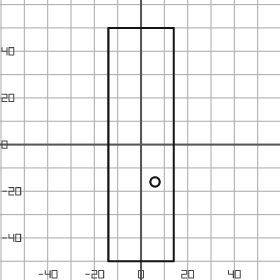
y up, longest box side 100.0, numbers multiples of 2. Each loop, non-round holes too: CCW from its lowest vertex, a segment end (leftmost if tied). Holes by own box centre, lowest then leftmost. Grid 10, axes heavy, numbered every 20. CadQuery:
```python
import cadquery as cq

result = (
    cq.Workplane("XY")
    .moveTo(-14.0, -50.0)
    .lineTo(14.0, -50.0)
    .lineTo(14.0, 50.0)
    .lineTo(-14.0, 50.0)
    .close()
    .moveTo(6.0, -16.0)
    .circle(2.0)
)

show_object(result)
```